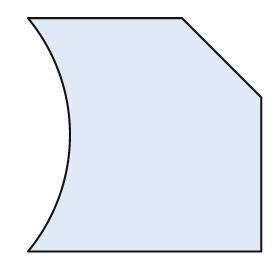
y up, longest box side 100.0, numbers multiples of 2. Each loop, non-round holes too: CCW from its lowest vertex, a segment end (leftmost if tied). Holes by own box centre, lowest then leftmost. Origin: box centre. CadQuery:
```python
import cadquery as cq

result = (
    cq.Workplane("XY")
    .moveTo(-50.0, -50.0)
    .lineTo(50.0, -50.0)
    .lineTo(50.0, 16.0)
    .lineTo(16.0, 50.0)
    .lineTo(-50.0, 50.0)
    .threePointArc((-32.0, 0.0), (-50.0, -50.0))
    .close()
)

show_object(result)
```